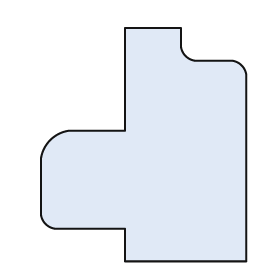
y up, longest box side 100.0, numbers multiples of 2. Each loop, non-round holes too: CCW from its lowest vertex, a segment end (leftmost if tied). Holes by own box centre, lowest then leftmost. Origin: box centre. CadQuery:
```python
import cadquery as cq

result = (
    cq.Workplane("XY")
    .moveTo(-8.0, -50.0)
    .lineTo(44.0, -50.0)
    .lineTo(44.0, 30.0)
    .threePointArc((42.0, 34.0), (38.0, 36.0))
    .lineTo(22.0, 36.0)
    .threePointArc((18.0, 38.0), (16.0, 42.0))
    .lineTo(16.0, 50.0)
    .lineTo(-8.0, 50.0)
    .lineTo(-8.0, 6.0)
    .lineTo(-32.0, 6.0)
    .threePointArc((-40.0, 2.0), (-44.0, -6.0))
    .lineTo(-44.0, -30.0)
    .threePointArc((-42.0, -34.0), (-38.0, -36.0))
    .lineTo(-8.0, -36.0)
    .close()
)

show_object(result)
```